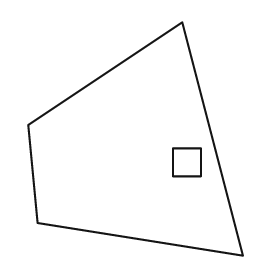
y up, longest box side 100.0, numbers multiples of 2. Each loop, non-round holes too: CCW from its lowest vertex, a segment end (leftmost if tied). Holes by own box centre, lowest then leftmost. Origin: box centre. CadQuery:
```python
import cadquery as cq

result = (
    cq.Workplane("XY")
    .moveTo(46.0, -50.0)
    .lineTo(20.0, 50.0)
    .lineTo(-46.0, 6.0)
    .lineTo(-42.0, -36.0)
    .close()
    .moveTo(16.0, -16.0)
    .lineTo(28.0, -16.0)
    .lineTo(28.0, -4.0)
    .lineTo(16.0, -4.0)
    .close()
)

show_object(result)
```